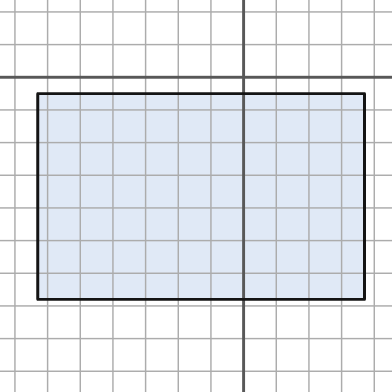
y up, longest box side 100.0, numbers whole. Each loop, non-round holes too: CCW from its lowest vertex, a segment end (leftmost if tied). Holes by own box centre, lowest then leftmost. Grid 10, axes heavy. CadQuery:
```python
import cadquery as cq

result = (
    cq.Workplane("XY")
    .moveTo(-63.0, -68.0)
    .lineTo(37.0, -68.0)
    .lineTo(37.0, -5.0)
    .lineTo(-63.0, -5.0)
    .close()
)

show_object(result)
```